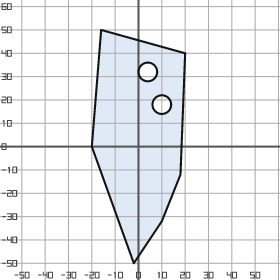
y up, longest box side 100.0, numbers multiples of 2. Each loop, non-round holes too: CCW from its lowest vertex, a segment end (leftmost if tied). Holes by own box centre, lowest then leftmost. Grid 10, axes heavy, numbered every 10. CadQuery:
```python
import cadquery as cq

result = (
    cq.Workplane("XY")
    .moveTo(-2.0, -50.0)
    .lineTo(10.0, -32.0)
    .lineTo(18.0, -12.0)
    .lineTo(20.0, 40.0)
    .lineTo(-16.0, 50.0)
    .lineTo(-20.0, 0.0)
    .close()
    .moveTo(10.0, 18.0)
    .circle(4.0)
    .moveTo(4.0, 32.0)
    .circle(4.0)
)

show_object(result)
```